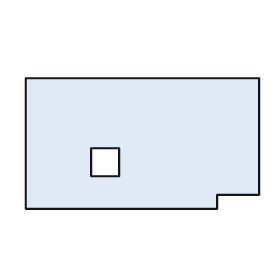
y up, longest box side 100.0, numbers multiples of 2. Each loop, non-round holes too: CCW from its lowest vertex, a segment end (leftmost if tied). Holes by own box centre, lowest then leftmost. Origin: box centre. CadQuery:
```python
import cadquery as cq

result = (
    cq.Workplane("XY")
    .moveTo(-50.0, -28.0)
    .lineTo(32.0, -28.0)
    .lineTo(32.0, -22.0)
    .lineTo(50.0, -22.0)
    .lineTo(50.0, 28.0)
    .lineTo(-50.0, 28.0)
    .close()
    .moveTo(-22.0, -14.0)
    .lineTo(-10.0, -14.0)
    .lineTo(-10.0, -2.0)
    .lineTo(-22.0, -2.0)
    .close()
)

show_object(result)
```